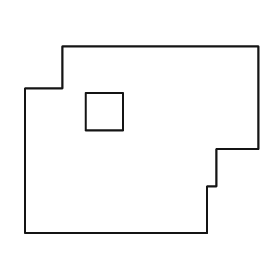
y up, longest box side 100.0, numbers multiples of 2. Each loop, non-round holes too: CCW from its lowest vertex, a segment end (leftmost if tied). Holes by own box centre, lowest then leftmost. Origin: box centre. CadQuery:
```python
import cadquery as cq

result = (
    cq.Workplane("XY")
    .moveTo(-50.0, -40.0)
    .lineTo(28.0, -40.0)
    .lineTo(28.0, -20.0)
    .lineTo(32.0, -20.0)
    .lineTo(32.0, -4.0)
    .lineTo(50.0, -4.0)
    .lineTo(50.0, 40.0)
    .lineTo(-34.0, 40.0)
    .lineTo(-34.0, 22.0)
    .lineTo(-50.0, 22.0)
    .close()
    .moveTo(-24.0, 4.0)
    .lineTo(-8.0, 4.0)
    .lineTo(-8.0, 20.0)
    .lineTo(-24.0, 20.0)
    .close()
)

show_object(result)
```